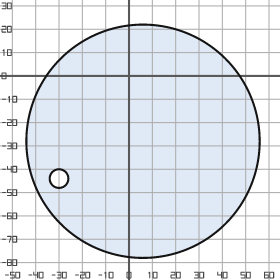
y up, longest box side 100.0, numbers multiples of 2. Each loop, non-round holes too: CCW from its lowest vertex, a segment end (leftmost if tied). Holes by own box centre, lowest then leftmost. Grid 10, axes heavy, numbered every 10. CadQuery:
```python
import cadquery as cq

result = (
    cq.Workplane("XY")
    .moveTo(6.0, -28.0)
    .circle(50.0)
    .moveTo(-30.0, -44.0)
    .circle(4.0)
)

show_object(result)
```